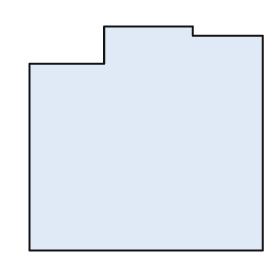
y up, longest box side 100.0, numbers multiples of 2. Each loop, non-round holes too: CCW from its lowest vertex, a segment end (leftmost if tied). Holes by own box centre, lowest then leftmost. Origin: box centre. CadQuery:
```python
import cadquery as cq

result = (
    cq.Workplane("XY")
    .moveTo(-50.0, -48.0)
    .lineTo(50.0, -48.0)
    .lineTo(50.0, 44.0)
    .lineTo(20.0, 44.0)
    .lineTo(20.0, 48.0)
    .lineTo(-18.0, 48.0)
    .lineTo(-18.0, 32.0)
    .lineTo(-50.0, 32.0)
    .close()
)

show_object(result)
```